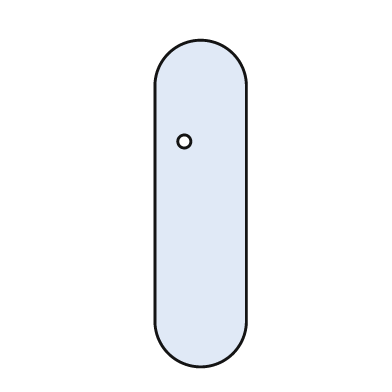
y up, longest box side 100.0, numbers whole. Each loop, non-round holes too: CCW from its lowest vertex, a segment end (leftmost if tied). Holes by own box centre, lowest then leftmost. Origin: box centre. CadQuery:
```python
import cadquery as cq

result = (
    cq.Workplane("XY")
    .moveTo(-14.0, -36.0)
    .threePointArc((0.0, -50.0), (14.0, -36.0))
    .lineTo(14.0, 36.0)
    .threePointArc((0.0, 50.0), (-14.0, 36.0))
    .close()
    .moveTo(-5.0, 19.0)
    .circle(2.0)
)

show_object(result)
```